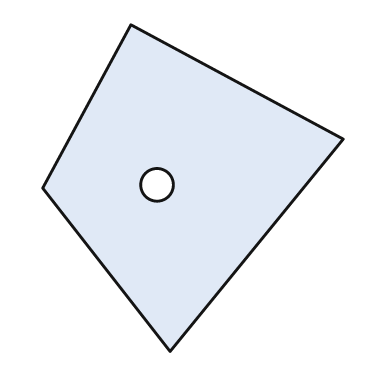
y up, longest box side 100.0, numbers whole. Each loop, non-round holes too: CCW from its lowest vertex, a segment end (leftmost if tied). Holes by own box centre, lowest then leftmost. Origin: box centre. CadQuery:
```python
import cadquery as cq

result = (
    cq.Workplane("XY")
    .moveTo(-7.0, -50.0)
    .lineTo(46.0, 15.0)
    .lineTo(-19.0, 50.0)
    .lineTo(-46.0, 0.0)
    .close()
    .moveTo(-11.0, 1.0)
    .circle(5.0)
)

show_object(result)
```